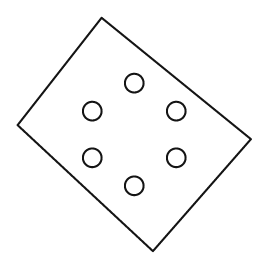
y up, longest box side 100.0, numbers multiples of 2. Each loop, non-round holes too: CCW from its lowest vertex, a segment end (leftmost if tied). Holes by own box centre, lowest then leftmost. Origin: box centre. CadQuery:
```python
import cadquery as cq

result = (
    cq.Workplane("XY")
    .moveTo(8.0, -50.0)
    .lineTo(50.0, -2.0)
    .lineTo(-14.0, 50.0)
    .lineTo(-50.0, 4.0)
    .close()
    .moveTo(0.0, -22.0)
    .circle(4.0)
    .moveTo(-18.0, -10.0)
    .circle(4.0)
    .moveTo(18.0, -10.0)
    .circle(4.0)
    .moveTo(-18.0, 10.0)
    .circle(4.0)
    .moveTo(18.0, 10.0)
    .circle(4.0)
    .moveTo(0.0, 22.0)
    .circle(4.0)
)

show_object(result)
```